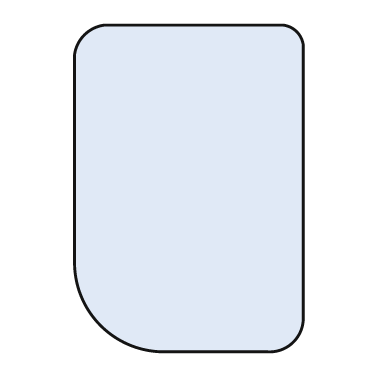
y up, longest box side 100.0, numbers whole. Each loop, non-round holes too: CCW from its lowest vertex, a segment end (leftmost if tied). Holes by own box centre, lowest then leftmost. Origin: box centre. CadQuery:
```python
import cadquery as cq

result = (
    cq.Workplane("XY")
    .moveTo(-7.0, -50.0)
    .lineTo(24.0, -50.0)
    .threePointArc((32.0, -47.0), (35.0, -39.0))
    .lineTo(35.0, 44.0)
    .threePointArc((33.0, 48.0), (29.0, 50.0))
    .lineTo(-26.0, 50.0)
    .threePointArc((-32.0, 47.0), (-35.0, 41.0))
    .lineTo(-35.0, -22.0)
    .threePointArc((-27.0, -42.0), (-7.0, -50.0))
    .close()
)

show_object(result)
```